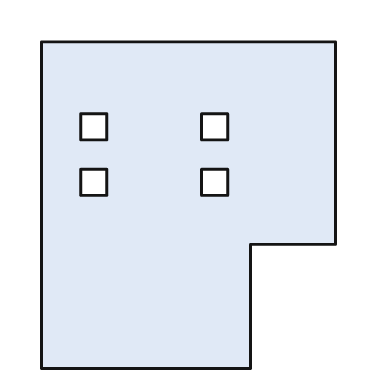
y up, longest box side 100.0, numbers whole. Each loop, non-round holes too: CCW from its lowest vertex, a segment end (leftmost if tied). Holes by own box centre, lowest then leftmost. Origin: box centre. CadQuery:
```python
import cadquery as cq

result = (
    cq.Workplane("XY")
    .moveTo(-45.0, -50.0)
    .lineTo(19.0, -50.0)
    .lineTo(19.0, -12.0)
    .lineTo(45.0, -12.0)
    .lineTo(45.0, 50.0)
    .lineTo(-45.0, 50.0)
    .close()
    .moveTo(-33.0, 3.0)
    .lineTo(-25.0, 3.0)
    .lineTo(-25.0, 11.0)
    .lineTo(-33.0, 11.0)
    .close()
    .moveTo(4.0, 3.0)
    .lineTo(12.0, 3.0)
    .lineTo(12.0, 11.0)
    .lineTo(4.0, 11.0)
    .close()
    .moveTo(-33.0, 20.0)
    .lineTo(-25.0, 20.0)
    .lineTo(-25.0, 28.0)
    .lineTo(-33.0, 28.0)
    .close()
    .moveTo(4.0, 20.0)
    .lineTo(12.0, 20.0)
    .lineTo(12.0, 28.0)
    .lineTo(4.0, 28.0)
    .close()
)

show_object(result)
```